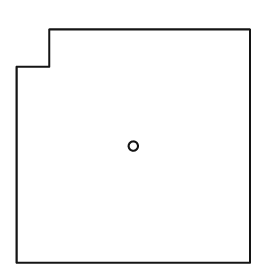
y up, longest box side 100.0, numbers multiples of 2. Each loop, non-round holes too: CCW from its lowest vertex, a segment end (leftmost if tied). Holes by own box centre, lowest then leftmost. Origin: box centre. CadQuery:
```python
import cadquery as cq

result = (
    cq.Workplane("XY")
    .moveTo(-50.0, -50.0)
    .lineTo(50.0, -50.0)
    .lineTo(50.0, 50.0)
    .lineTo(-36.0, 50.0)
    .lineTo(-36.0, 34.0)
    .lineTo(-50.0, 34.0)
    .close()
    .moveTo(0.0, 0.0)
    .circle(2.0)
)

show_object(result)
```